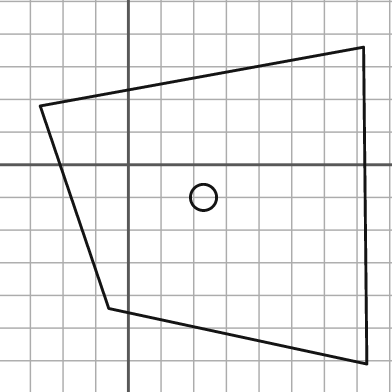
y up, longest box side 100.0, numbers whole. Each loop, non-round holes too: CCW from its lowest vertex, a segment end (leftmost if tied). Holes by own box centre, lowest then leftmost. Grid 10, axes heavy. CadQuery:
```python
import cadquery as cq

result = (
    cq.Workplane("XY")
    .moveTo(73.0, -61.0)
    .lineTo(72.0, 36.0)
    .lineTo(-27.0, 18.0)
    .lineTo(-6.0, -44.0)
    .close()
    .moveTo(23.0, -10.0)
    .circle(4.0)
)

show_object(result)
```